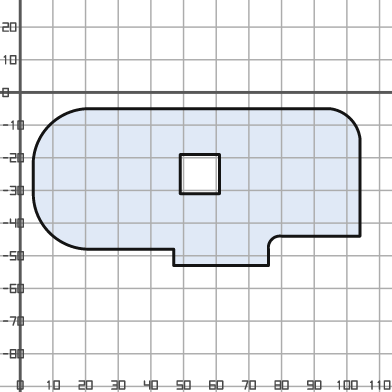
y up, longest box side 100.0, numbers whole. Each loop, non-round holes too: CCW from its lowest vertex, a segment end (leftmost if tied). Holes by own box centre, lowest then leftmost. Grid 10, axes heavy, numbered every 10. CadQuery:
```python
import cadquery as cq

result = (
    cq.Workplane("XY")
    .moveTo(47.0, -53.0)
    .lineTo(76.0, -53.0)
    .lineTo(76.0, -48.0)
    .threePointArc((77.0, -45.0), (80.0, -44.0))
    .lineTo(104.0, -44.0)
    .lineTo(104.0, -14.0)
    .threePointArc((101.0, -8.0), (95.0, -5.0))
    .lineTo(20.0, -5.0)
    .threePointArc((9.0, -10.0), (4.0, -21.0))
    .lineTo(4.0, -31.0)
    .threePointArc((9.0, -43.0), (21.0, -48.0))
    .lineTo(47.0, -48.0)
    .close()
    .moveTo(49.0, -31.0)
    .lineTo(61.0, -31.0)
    .lineTo(61.0, -19.0)
    .lineTo(49.0, -19.0)
    .close()
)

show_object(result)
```